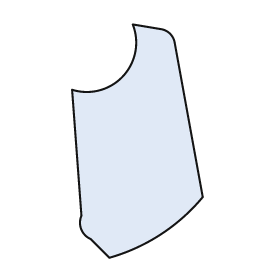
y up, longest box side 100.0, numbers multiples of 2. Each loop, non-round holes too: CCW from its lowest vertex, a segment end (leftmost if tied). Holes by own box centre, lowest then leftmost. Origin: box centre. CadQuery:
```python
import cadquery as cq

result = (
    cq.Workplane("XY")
    .moveTo(-12.0, -50.0)
    .threePointArc((10.0, -40.0), (28.0, -24.0))
    .lineTo(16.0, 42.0)
    .threePointArc((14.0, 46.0), (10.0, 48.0))
    .lineTo(-2.0, 50.0)
    .threePointArc((-6.0, 28.0), (-28.0, 22.0))
    .lineTo(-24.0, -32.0)
    .threePointArc((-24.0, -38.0), (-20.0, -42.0))
    .close()
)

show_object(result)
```